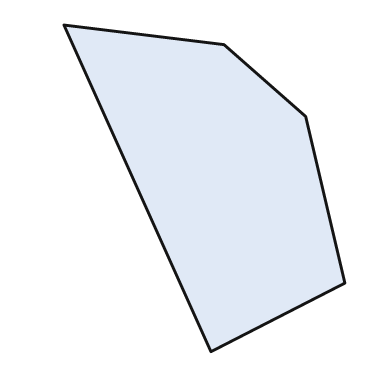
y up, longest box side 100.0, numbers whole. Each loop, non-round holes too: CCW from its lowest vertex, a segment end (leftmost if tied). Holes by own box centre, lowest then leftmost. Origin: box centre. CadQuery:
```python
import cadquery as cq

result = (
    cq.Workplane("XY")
    .moveTo(2.0, -50.0)
    .lineTo(43.0, -29.0)
    .lineTo(31.0, 22.0)
    .lineTo(6.0, 44.0)
    .lineTo(-43.0, 50.0)
    .close()
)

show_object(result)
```